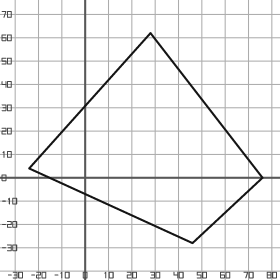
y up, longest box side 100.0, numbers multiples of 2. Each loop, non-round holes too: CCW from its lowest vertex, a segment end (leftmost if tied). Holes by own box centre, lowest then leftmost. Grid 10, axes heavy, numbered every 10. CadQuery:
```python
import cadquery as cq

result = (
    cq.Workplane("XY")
    .moveTo(46.0, -28.0)
    .lineTo(76.0, 0.0)
    .lineTo(28.0, 62.0)
    .lineTo(-24.0, 4.0)
    .close()
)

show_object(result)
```